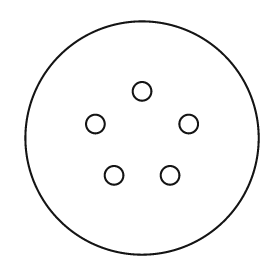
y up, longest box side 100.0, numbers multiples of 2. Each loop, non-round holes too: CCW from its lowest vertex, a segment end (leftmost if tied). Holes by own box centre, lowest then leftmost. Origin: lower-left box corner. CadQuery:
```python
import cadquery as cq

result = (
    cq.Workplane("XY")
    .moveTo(50.0, 50.0)
    .circle(50.0)
    .moveTo(38.0, 34.0)
    .circle(4.0)
    .moveTo(62.0, 34.0)
    .circle(4.0)
    .moveTo(30.0, 56.0)
    .circle(4.0)
    .moveTo(70.0, 56.0)
    .circle(4.0)
    .moveTo(50.0, 70.0)
    .circle(4.0)
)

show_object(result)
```